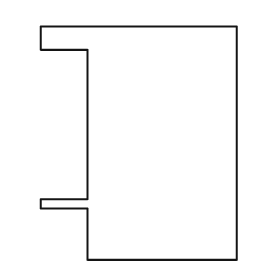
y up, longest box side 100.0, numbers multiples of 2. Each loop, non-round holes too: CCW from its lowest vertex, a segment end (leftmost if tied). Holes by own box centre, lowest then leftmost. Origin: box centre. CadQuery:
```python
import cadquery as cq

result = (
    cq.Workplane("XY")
    .moveTo(-22.0, -50.0)
    .lineTo(42.0, -50.0)
    .lineTo(42.0, 50.0)
    .lineTo(-42.0, 50.0)
    .lineTo(-42.0, 40.0)
    .lineTo(-22.0, 40.0)
    .lineTo(-22.0, -24.0)
    .lineTo(-42.0, -24.0)
    .lineTo(-42.0, -28.0)
    .lineTo(-22.0, -28.0)
    .close()
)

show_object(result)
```